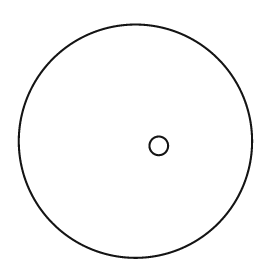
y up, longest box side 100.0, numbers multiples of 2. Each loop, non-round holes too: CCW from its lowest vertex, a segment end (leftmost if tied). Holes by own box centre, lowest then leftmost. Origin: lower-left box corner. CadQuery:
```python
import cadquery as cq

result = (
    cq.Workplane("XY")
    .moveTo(50.0, 50.0)
    .circle(50.0)
    .moveTo(60.0, 48.0)
    .circle(4.0)
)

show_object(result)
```